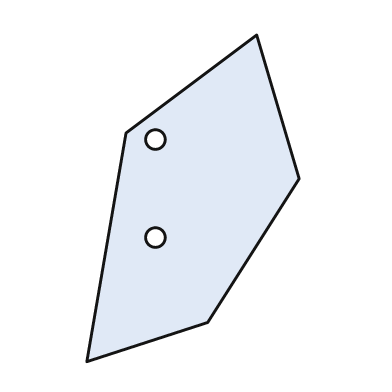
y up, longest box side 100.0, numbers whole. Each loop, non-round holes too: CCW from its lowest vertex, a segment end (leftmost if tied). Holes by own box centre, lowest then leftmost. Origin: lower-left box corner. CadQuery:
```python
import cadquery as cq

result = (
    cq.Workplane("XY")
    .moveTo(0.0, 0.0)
    .lineTo(37.0, 12.0)
    .lineTo(65.0, 56.0)
    .lineTo(52.0, 100.0)
    .lineTo(12.0, 70.0)
    .close()
    .moveTo(21.0, 38.0)
    .circle(3.0)
    .moveTo(21.0, 68.0)
    .circle(3.0)
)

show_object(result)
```